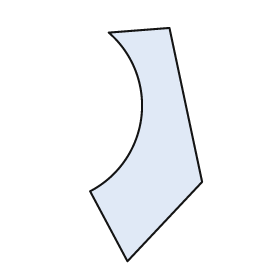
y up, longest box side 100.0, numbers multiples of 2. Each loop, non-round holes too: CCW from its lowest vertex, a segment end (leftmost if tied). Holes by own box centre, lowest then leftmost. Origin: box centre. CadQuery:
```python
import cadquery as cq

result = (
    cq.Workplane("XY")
    .moveTo(-8.0, -50.0)
    .lineTo(24.0, -16.0)
    .lineTo(10.0, 50.0)
    .lineTo(-16.0, 48.0)
    .threePointArc((-2.0, 12.0), (-24.0, -20.0))
    .close()
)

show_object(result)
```